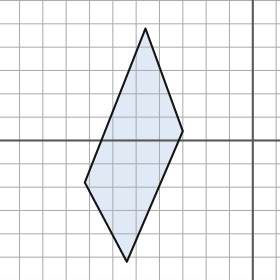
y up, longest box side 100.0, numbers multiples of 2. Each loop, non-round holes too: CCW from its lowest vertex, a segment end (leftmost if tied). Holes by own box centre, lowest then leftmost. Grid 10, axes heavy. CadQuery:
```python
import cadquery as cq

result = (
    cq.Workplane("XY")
    .moveTo(-54.0, -52.0)
    .lineTo(-30.0, 4.0)
    .lineTo(-46.0, 48.0)
    .lineTo(-72.0, -18.0)
    .close()
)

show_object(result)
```